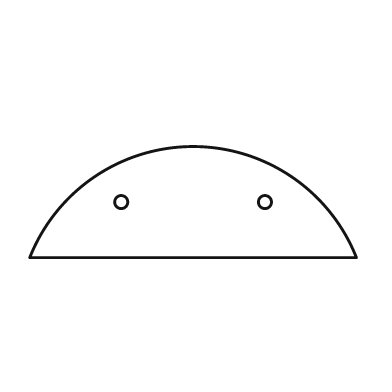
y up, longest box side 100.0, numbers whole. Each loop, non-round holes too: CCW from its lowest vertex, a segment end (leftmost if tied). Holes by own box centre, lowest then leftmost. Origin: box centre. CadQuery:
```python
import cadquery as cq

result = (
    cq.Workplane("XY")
    .moveTo(-50.0, -17.0)
    .lineTo(50.0, -17.0)
    .threePointArc((0.0, 17.0), (-50.0, -17.0))
    .close()
    .moveTo(-22.0, 0.0)
    .circle(2.0)
    .moveTo(22.0, 0.0)
    .circle(2.0)
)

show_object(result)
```